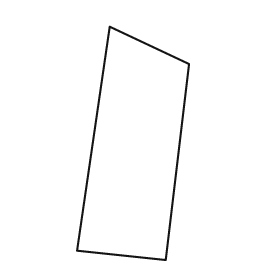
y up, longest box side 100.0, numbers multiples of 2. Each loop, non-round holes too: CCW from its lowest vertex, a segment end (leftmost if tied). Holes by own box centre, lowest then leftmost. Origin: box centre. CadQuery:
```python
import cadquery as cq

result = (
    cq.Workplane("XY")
    .moveTo(14.0, -50.0)
    .lineTo(24.0, 34.0)
    .lineTo(-10.0, 50.0)
    .lineTo(-24.0, -46.0)
    .close()
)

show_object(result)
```